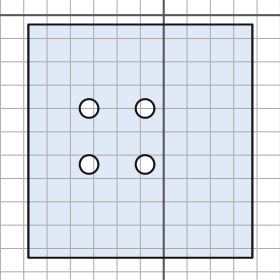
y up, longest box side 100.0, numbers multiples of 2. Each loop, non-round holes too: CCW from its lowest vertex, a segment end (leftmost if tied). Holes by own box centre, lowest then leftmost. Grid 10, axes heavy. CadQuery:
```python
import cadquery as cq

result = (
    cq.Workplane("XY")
    .moveTo(-58.0, -104.0)
    .lineTo(38.0, -104.0)
    .lineTo(38.0, -4.0)
    .lineTo(-58.0, -4.0)
    .close()
    .moveTo(-32.0, -64.0)
    .circle(4.0)
    .moveTo(-8.0, -64.0)
    .circle(4.0)
    .moveTo(-32.0, -40.0)
    .circle(4.0)
    .moveTo(-8.0, -40.0)
    .circle(4.0)
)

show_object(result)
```